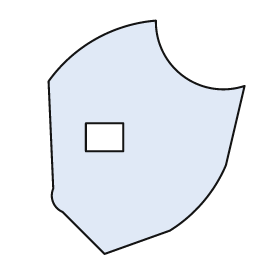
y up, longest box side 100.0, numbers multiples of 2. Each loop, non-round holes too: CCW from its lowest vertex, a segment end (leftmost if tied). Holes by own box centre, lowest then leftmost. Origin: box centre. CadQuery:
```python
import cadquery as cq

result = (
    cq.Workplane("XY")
    .moveTo(-18.0, -50.0)
    .lineTo(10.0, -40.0)
    .threePointArc((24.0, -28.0), (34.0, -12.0))
    .lineTo(42.0, 22.0)
    .threePointArc((16.0, 26.0), (4.0, 50.0))
    .threePointArc((-22.0, 42.0), (-42.0, 24.0))
    .lineTo(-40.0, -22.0)
    .threePointArc((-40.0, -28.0), (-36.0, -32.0))
    .close()
    .moveTo(-26.0, -6.0)
    .lineTo(-10.0, -6.0)
    .lineTo(-10.0, 6.0)
    .lineTo(-26.0, 6.0)
    .close()
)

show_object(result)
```